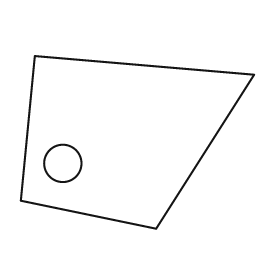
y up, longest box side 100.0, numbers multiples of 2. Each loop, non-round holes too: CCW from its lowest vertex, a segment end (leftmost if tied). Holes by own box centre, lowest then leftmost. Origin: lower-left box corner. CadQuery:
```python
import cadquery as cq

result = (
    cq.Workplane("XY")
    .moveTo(58.0, 0.0)
    .lineTo(100.0, 66.0)
    .lineTo(6.0, 74.0)
    .lineTo(0.0, 12.0)
    .close()
    .moveTo(18.0, 28.0)
    .circle(8.0)
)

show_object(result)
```